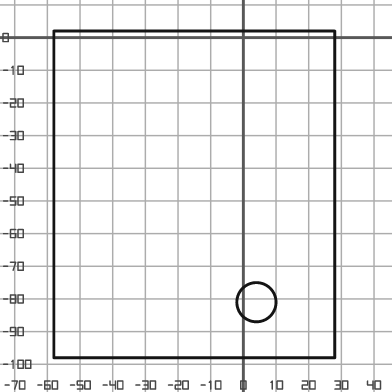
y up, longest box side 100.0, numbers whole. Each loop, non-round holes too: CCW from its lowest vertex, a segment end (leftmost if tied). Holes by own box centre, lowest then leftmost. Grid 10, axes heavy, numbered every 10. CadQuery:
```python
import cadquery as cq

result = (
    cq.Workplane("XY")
    .moveTo(-58.0, -98.0)
    .lineTo(28.0, -98.0)
    .lineTo(28.0, 2.0)
    .lineTo(-58.0, 2.0)
    .close()
    .moveTo(4.0, -81.0)
    .circle(6.0)
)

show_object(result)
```